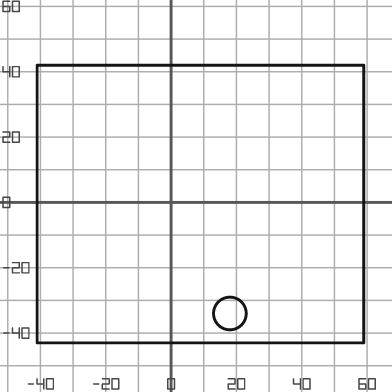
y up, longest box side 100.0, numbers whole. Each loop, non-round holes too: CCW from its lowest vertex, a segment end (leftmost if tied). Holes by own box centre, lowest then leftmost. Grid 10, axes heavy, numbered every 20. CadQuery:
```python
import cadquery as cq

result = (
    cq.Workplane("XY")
    .moveTo(-41.0, -43.0)
    .lineTo(59.0, -43.0)
    .lineTo(59.0, 42.0)
    .lineTo(-41.0, 42.0)
    .close()
    .moveTo(18.0, -34.0)
    .circle(5.0)
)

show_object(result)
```